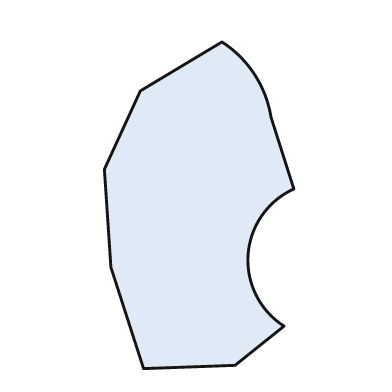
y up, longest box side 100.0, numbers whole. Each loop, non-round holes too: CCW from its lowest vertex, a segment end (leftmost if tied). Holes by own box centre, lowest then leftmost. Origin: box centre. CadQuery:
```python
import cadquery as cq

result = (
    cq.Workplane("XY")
    .moveTo(-17.0, -50.0)
    .lineTo(11.0, -49.0)
    .lineTo(26.0, -37.0)
    .threePointArc((15.0, -15.0), (29.0, 5.0))
    .lineTo(22.0, 27.0)
    .threePointArc((17.0, 40.0), (7.0, 50.0))
    .lineTo(-18.0, 35.0)
    .lineTo(-29.0, 11.0)
    .lineTo(-27.0, -19.0)
    .close()
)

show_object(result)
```